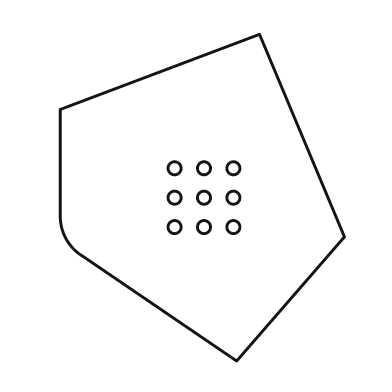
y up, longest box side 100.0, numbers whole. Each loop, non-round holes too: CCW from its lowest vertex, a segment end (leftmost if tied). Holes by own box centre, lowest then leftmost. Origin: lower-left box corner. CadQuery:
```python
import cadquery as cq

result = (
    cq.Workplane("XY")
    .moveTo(54.0, 0.0)
    .lineTo(87.0, 38.0)
    .lineTo(61.0, 100.0)
    .lineTo(0.0, 77.0)
    .lineTo(0.0, 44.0)
    .threePointArc((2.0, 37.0), (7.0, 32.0))
    .close()
    .moveTo(35.0, 41.0)
    .circle(2.0)
    .moveTo(44.0, 41.0)
    .circle(2.0)
    .moveTo(53.0, 41.0)
    .circle(2.0)
    .moveTo(35.0, 50.0)
    .circle(2.0)
    .moveTo(44.0, 50.0)
    .circle(2.0)
    .moveTo(53.0, 50.0)
    .circle(2.0)
    .moveTo(35.0, 59.0)
    .circle(2.0)
    .moveTo(44.0, 59.0)
    .circle(2.0)
    .moveTo(53.0, 59.0)
    .circle(2.0)
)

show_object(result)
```